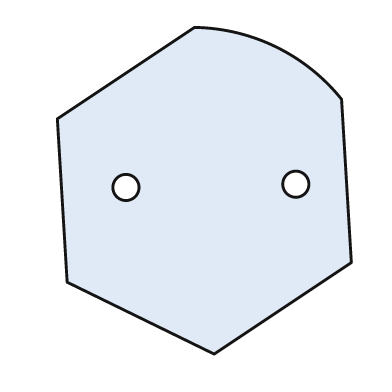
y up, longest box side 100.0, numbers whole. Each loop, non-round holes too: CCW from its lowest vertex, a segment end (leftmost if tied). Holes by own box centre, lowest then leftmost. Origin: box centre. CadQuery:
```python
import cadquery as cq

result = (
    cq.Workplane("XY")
    .moveTo(3.0, -50.0)
    .lineTo(45.0, -22.0)
    .lineTo(42.0, 28.0)
    .threePointArc((22.0, 44.0), (-3.0, 50.0))
    .lineTo(-45.0, 22.0)
    .lineTo(-42.0, -28.0)
    .close()
    .moveTo(-24.0, 1.0)
    .circle(4.0)
    .moveTo(28.0, 2.0)
    .circle(4.0)
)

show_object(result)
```